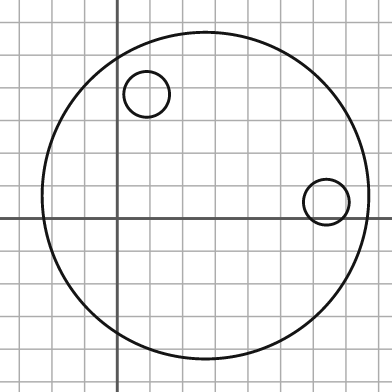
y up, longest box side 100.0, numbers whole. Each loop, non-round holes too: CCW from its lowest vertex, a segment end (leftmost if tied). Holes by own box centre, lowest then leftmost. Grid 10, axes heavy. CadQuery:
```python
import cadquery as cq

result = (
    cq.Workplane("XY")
    .moveTo(27.0, 7.0)
    .circle(50.0)
    .moveTo(64.0, 5.0)
    .circle(7.0)
    .moveTo(9.0, 38.0)
    .circle(7.0)
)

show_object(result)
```